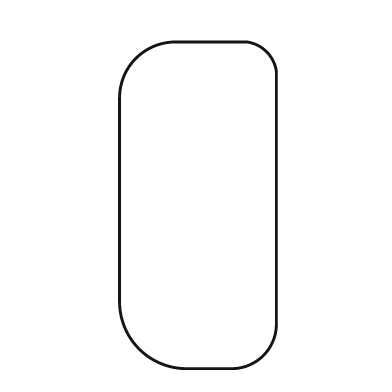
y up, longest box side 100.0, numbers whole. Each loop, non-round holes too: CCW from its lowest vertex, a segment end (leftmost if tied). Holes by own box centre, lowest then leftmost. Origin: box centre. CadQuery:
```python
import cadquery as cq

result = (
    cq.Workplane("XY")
    .moveTo(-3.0, -50.0)
    .lineTo(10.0, -50.0)
    .threePointArc((20.0, -46.0), (24.0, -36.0))
    .lineTo(24.0, 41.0)
    .threePointArc((21.0, 47.0), (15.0, 50.0))
    .lineTo(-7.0, 50.0)
    .threePointArc((-19.0, 45.0), (-24.0, 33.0))
    .lineTo(-24.0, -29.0)
    .threePointArc((-18.0, -44.0), (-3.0, -50.0))
    .close()
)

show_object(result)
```